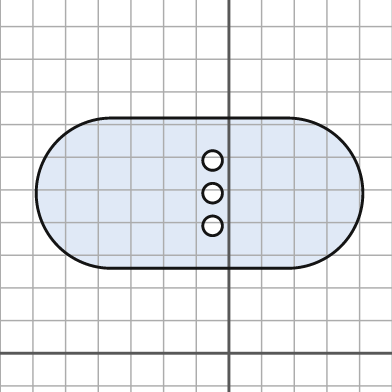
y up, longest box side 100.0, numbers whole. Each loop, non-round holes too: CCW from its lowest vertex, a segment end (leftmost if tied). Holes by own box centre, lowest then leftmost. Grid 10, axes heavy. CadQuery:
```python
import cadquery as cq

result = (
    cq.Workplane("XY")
    .moveTo(-36.0, 26.0)
    .lineTo(18.0, 26.0)
    .threePointArc((41.0, 49.0), (18.0, 72.0))
    .lineTo(-36.0, 72.0)
    .threePointArc((-59.0, 49.0), (-36.0, 26.0))
    .close()
    .moveTo(-5.0, 39.0)
    .circle(3.0)
    .moveTo(-5.0, 49.0)
    .circle(3.0)
    .moveTo(-5.0, 59.0)
    .circle(3.0)
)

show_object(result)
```